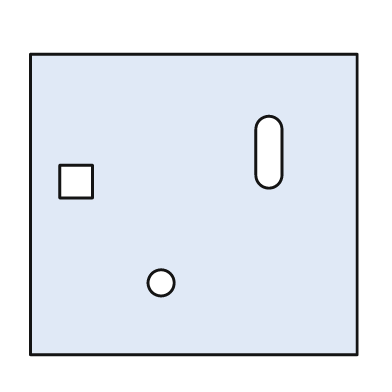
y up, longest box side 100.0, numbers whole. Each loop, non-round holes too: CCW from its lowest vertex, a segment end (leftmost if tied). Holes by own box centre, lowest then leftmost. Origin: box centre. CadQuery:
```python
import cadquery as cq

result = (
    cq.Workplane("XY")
    .moveTo(-50.0, -46.0)
    .lineTo(50.0, -46.0)
    .lineTo(50.0, 46.0)
    .lineTo(-50.0, 46.0)
    .close()
    .moveTo(-10.0, -24.0)
    .circle(4.0)
    .moveTo(-41.0, 2.0)
    .lineTo(-31.0, 2.0)
    .lineTo(-31.0, 12.0)
    .lineTo(-41.0, 12.0)
    .close()
    .moveTo(19.0, 9.0)
    .threePointArc((23.0, 5.0), (27.0, 9.0))
    .lineTo(27.0, 23.0)
    .threePointArc((23.0, 27.0), (19.0, 23.0))
    .close()
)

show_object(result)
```